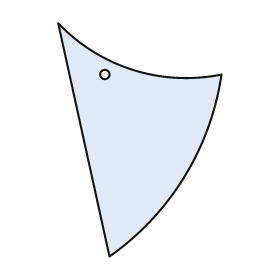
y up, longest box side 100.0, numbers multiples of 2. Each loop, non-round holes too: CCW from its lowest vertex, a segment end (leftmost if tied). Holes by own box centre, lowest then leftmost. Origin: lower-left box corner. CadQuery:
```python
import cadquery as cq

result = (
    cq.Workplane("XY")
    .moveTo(22.0, 0.0)
    .threePointArc((54.0, 34.0), (70.0, 78.0))
    .threePointArc((32.0, 80.0), (0.0, 100.0))
    .close()
    .moveTo(20.0, 78.0)
    .circle(2.0)
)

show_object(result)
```